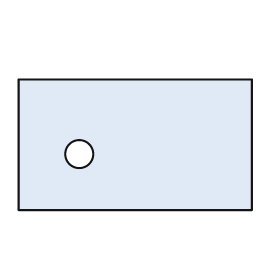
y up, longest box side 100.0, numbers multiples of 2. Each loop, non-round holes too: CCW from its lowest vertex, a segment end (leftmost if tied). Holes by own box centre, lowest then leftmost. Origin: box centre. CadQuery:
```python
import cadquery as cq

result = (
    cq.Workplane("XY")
    .moveTo(-50.0, -28.0)
    .lineTo(50.0, -28.0)
    .lineTo(50.0, 28.0)
    .lineTo(-50.0, 28.0)
    .close()
    .moveTo(-24.0, -4.0)
    .circle(6.0)
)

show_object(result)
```